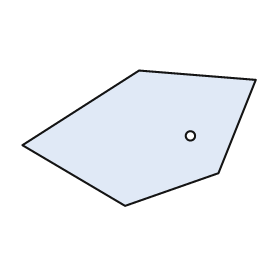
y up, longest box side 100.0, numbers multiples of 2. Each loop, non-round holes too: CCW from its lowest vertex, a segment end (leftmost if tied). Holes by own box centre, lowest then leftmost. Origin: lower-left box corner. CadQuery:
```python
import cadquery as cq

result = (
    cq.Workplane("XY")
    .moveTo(44.0, 0.0)
    .lineTo(84.0, 14.0)
    .lineTo(100.0, 54.0)
    .lineTo(50.0, 58.0)
    .lineTo(0.0, 26.0)
    .close()
    .moveTo(72.0, 30.0)
    .circle(2.0)
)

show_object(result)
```